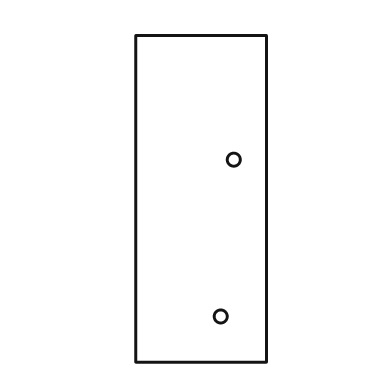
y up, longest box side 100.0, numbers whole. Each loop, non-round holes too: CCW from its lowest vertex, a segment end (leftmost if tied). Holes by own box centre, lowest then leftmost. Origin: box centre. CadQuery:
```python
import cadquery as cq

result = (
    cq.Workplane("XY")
    .moveTo(-20.0, -50.0)
    .lineTo(20.0, -50.0)
    .lineTo(20.0, 50.0)
    .lineTo(-20.0, 50.0)
    .close()
    .moveTo(6.0, -36.0)
    .circle(2.0)
    .moveTo(10.0, 12.0)
    .circle(2.0)
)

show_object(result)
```